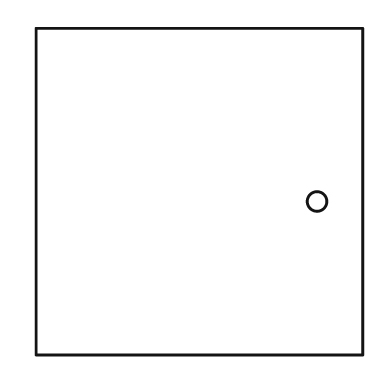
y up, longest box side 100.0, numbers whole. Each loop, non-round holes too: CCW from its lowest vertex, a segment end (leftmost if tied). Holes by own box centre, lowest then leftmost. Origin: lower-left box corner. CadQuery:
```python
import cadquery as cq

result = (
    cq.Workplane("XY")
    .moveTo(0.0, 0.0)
    .lineTo(100.0, 0.0)
    .lineTo(100.0, 100.0)
    .lineTo(0.0, 100.0)
    .close()
    .moveTo(86.0, 47.0)
    .circle(3.0)
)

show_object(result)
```